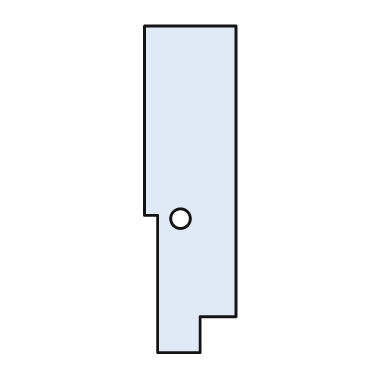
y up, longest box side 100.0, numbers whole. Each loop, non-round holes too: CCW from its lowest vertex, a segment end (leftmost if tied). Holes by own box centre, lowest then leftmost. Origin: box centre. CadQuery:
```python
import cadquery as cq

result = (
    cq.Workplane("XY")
    .moveTo(-10.0, -50.0)
    .lineTo(3.0, -50.0)
    .lineTo(3.0, -39.0)
    .lineTo(14.0, -39.0)
    .lineTo(14.0, 50.0)
    .lineTo(-14.0, 50.0)
    .lineTo(-14.0, -8.0)
    .lineTo(-10.0, -8.0)
    .close()
    .moveTo(-3.0, -9.0)
    .circle(3.0)
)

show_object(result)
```